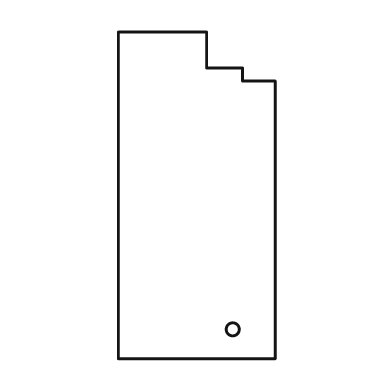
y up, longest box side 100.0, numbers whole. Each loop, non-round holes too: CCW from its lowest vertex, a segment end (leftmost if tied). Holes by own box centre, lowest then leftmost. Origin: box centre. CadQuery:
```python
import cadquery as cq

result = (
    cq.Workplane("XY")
    .moveTo(-24.0, -50.0)
    .lineTo(24.0, -50.0)
    .lineTo(24.0, 35.0)
    .lineTo(14.0, 35.0)
    .lineTo(14.0, 39.0)
    .lineTo(3.0, 39.0)
    .lineTo(3.0, 50.0)
    .lineTo(-24.0, 50.0)
    .close()
    .moveTo(11.0, -41.0)
    .circle(2.0)
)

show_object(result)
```